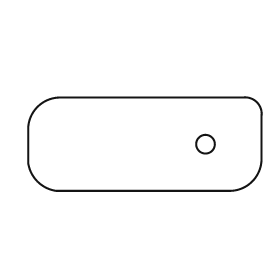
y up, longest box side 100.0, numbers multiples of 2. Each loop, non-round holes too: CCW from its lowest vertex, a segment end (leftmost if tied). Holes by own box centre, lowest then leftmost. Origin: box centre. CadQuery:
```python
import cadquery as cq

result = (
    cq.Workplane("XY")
    .moveTo(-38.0, -20.0)
    .lineTo(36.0, -20.0)
    .threePointArc((46.0, -16.0), (50.0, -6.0))
    .lineTo(50.0, 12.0)
    .threePointArc((48.0, 18.0), (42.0, 20.0))
    .lineTo(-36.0, 20.0)
    .threePointArc((-46.0, 16.0), (-50.0, 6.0))
    .lineTo(-50.0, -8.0)
    .threePointArc((-46.0, -16.0), (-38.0, -20.0))
    .close()
    .moveTo(26.0, 0.0)
    .circle(4.0)
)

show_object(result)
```